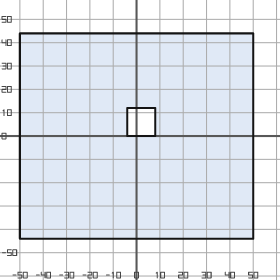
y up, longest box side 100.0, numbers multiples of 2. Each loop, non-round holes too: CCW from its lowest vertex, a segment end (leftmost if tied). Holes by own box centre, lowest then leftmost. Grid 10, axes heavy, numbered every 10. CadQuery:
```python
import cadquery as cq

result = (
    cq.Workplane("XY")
    .moveTo(-50.0, -44.0)
    .lineTo(50.0, -44.0)
    .lineTo(50.0, 44.0)
    .lineTo(-50.0, 44.0)
    .close()
    .moveTo(-4.0, 0.0)
    .lineTo(8.0, 0.0)
    .lineTo(8.0, 12.0)
    .lineTo(-4.0, 12.0)
    .close()
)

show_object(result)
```